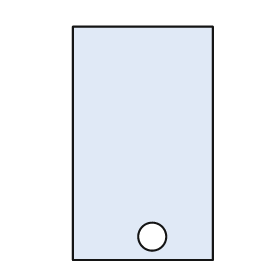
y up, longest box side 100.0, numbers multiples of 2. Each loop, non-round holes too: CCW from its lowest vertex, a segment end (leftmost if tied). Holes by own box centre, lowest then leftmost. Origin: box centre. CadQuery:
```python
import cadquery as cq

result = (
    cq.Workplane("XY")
    .moveTo(-30.0, -50.0)
    .lineTo(30.0, -50.0)
    .lineTo(30.0, 50.0)
    .lineTo(-30.0, 50.0)
    .close()
    .moveTo(4.0, -40.0)
    .circle(6.0)
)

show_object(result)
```